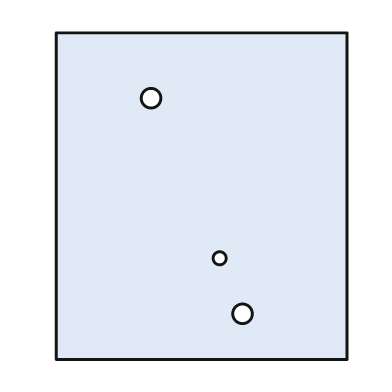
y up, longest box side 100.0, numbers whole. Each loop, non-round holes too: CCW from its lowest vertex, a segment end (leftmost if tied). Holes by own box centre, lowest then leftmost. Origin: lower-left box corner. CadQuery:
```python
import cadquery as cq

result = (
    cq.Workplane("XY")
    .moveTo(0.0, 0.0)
    .lineTo(89.0, 0.0)
    .lineTo(89.0, 100.0)
    .lineTo(0.0, 100.0)
    .close()
    .moveTo(57.0, 14.0)
    .circle(3.0)
    .moveTo(50.0, 31.0)
    .circle(2.0)
    .moveTo(29.0, 80.0)
    .circle(3.0)
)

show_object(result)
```